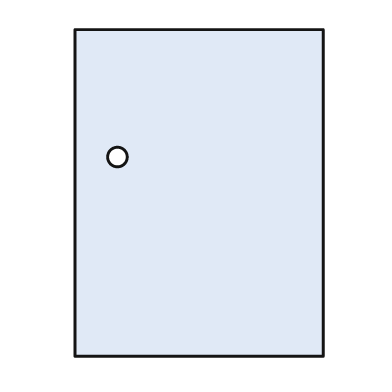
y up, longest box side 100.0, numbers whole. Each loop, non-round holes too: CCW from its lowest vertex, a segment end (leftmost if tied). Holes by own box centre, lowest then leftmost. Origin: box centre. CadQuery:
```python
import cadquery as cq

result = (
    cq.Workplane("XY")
    .moveTo(-38.0, -50.0)
    .lineTo(38.0, -50.0)
    .lineTo(38.0, 50.0)
    .lineTo(-38.0, 50.0)
    .close()
    .moveTo(-25.0, 11.0)
    .circle(3.0)
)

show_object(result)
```